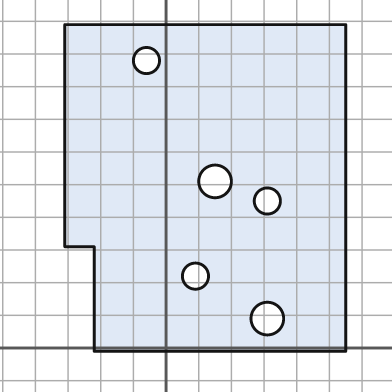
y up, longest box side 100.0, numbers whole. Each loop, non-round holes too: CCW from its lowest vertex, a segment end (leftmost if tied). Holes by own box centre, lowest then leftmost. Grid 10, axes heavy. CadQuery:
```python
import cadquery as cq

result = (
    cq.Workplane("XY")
    .moveTo(-22.0, -1.0)
    .lineTo(55.0, -1.0)
    .lineTo(55.0, 99.0)
    .lineTo(-31.0, 99.0)
    .lineTo(-31.0, 31.0)
    .lineTo(-22.0, 31.0)
    .close()
    .moveTo(31.0, 9.0)
    .circle(5.0)
    .moveTo(9.0, 22.0)
    .circle(4.0)
    .moveTo(31.0, 45.0)
    .circle(4.0)
    .moveTo(15.0, 51.0)
    .circle(5.0)
    .moveTo(-6.0, 88.0)
    .circle(4.0)
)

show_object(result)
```